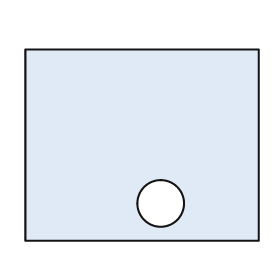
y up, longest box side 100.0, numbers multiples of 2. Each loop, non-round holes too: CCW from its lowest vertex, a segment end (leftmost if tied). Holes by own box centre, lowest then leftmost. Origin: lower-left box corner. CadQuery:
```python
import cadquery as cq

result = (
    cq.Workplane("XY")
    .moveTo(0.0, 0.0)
    .lineTo(100.0, 0.0)
    .lineTo(100.0, 82.0)
    .lineTo(0.0, 82.0)
    .close()
    .moveTo(58.0, 16.0)
    .circle(10.0)
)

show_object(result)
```